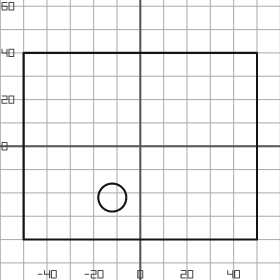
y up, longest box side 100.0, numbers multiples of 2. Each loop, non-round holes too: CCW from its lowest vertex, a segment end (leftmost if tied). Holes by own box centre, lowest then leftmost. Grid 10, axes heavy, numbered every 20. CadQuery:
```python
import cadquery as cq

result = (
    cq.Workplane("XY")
    .moveTo(-50.0, -40.0)
    .lineTo(50.0, -40.0)
    .lineTo(50.0, 40.0)
    .lineTo(-50.0, 40.0)
    .close()
    .moveTo(-12.0, -22.0)
    .circle(6.0)
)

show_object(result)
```